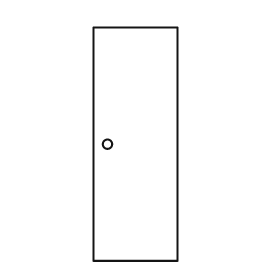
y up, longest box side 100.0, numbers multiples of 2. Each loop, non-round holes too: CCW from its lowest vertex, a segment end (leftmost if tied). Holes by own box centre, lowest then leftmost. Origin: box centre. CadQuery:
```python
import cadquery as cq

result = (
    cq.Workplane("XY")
    .moveTo(-18.0, -50.0)
    .lineTo(18.0, -50.0)
    .lineTo(18.0, 50.0)
    .lineTo(-18.0, 50.0)
    .close()
    .moveTo(-12.0, 0.0)
    .circle(2.0)
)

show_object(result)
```